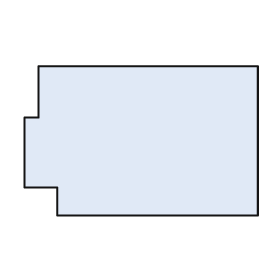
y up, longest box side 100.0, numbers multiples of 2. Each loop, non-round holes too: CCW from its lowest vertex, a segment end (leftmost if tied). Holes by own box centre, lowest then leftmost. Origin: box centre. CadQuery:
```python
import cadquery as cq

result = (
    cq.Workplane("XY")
    .moveTo(-36.0, -32.0)
    .lineTo(50.0, -32.0)
    .lineTo(50.0, 32.0)
    .lineTo(-44.0, 32.0)
    .lineTo(-44.0, 10.0)
    .lineTo(-50.0, 10.0)
    .lineTo(-50.0, -20.0)
    .lineTo(-36.0, -20.0)
    .close()
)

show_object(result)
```